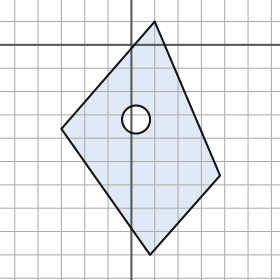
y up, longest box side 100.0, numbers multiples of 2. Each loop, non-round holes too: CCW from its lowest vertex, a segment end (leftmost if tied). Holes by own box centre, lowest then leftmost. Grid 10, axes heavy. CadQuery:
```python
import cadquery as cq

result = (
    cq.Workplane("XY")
    .moveTo(8.0, -90.0)
    .lineTo(38.0, -56.0)
    .lineTo(10.0, 10.0)
    .lineTo(-30.0, -36.0)
    .close()
    .moveTo(2.0, -32.0)
    .circle(6.0)
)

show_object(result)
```